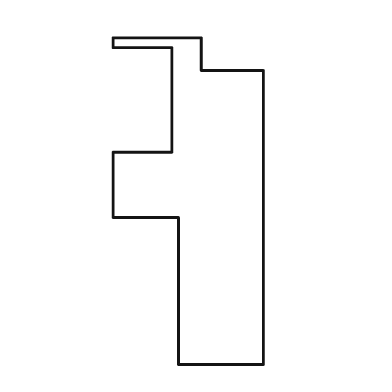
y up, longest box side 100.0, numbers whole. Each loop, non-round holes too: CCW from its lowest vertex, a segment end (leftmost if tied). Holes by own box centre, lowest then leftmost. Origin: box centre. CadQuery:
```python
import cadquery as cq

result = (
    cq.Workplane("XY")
    .moveTo(-3.0, -50.0)
    .lineTo(23.0, -50.0)
    .lineTo(23.0, 40.0)
    .lineTo(4.0, 40.0)
    .lineTo(4.0, 50.0)
    .lineTo(-23.0, 50.0)
    .lineTo(-23.0, 47.0)
    .lineTo(-5.0, 47.0)
    .lineTo(-5.0, 15.0)
    .lineTo(-23.0, 15.0)
    .lineTo(-23.0, -5.0)
    .lineTo(-3.0, -5.0)
    .close()
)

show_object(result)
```